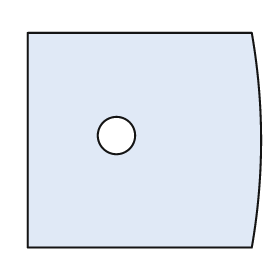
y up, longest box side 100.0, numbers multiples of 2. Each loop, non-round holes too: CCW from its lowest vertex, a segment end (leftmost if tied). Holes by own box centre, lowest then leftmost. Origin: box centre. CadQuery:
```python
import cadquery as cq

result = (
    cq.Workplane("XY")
    .moveTo(-50.0, -46.0)
    .lineTo(46.0, -46.0)
    .threePointArc((50.0, 0.0), (46.0, 46.0))
    .lineTo(-50.0, 46.0)
    .close()
    .moveTo(-12.0, 2.0)
    .circle(8.0)
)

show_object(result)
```